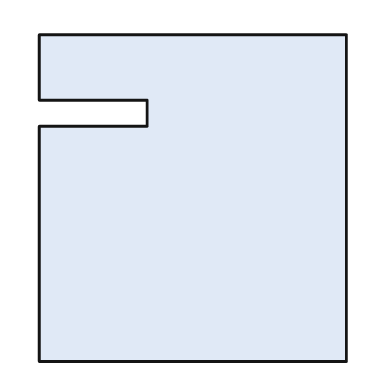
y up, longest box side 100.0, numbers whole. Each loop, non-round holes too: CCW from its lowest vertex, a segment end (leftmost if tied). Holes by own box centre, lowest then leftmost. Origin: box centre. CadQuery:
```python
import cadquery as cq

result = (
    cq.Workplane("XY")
    .moveTo(-47.0, -50.0)
    .lineTo(47.0, -50.0)
    .lineTo(47.0, 50.0)
    .lineTo(-47.0, 50.0)
    .lineTo(-47.0, 30.0)
    .lineTo(-14.0, 30.0)
    .lineTo(-14.0, 22.0)
    .lineTo(-47.0, 22.0)
    .close()
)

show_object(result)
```